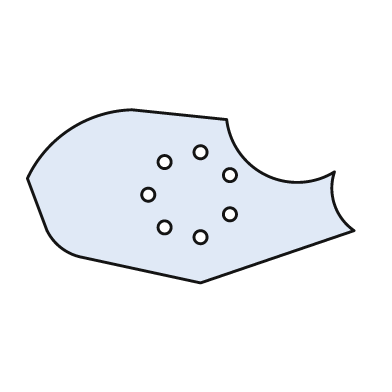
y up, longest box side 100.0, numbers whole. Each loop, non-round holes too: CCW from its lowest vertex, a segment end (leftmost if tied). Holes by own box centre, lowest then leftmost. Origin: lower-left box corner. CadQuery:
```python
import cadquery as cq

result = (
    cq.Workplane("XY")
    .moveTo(53.0, 0.0)
    .lineTo(100.0, 16.0)
    .threePointArc((94.0, 24.0), (94.0, 34.0))
    .threePointArc((73.0, 33.0), (61.0, 50.0))
    .lineTo(32.0, 53.0)
    .threePointArc((13.0, 47.0), (0.0, 32.0))
    .lineTo(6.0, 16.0)
    .threePointArc((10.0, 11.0), (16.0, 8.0))
    .close()
    .moveTo(53.0, 14.0)
    .circle(2.0)
    .moveTo(42.0, 17.0)
    .circle(2.0)
    .moveTo(62.0, 21.0)
    .circle(2.0)
    .moveTo(37.0, 27.0)
    .circle(2.0)
    .moveTo(62.0, 33.0)
    .circle(2.0)
    .moveTo(42.0, 37.0)
    .circle(2.0)
    .moveTo(53.0, 40.0)
    .circle(2.0)
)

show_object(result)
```